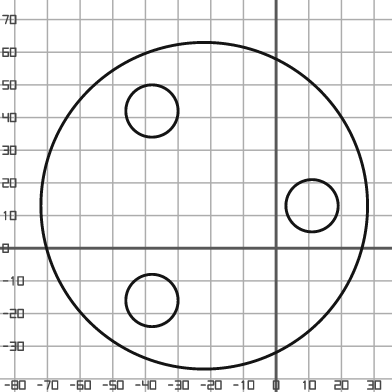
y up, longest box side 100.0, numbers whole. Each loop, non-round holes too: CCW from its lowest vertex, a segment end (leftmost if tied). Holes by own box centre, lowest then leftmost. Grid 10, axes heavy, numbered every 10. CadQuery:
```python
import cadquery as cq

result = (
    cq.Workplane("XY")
    .moveTo(-22.0, 13.0)
    .circle(50.0)
    .moveTo(-38.0, -16.0)
    .circle(8.0)
    .moveTo(11.0, 13.0)
    .circle(8.0)
    .moveTo(-38.0, 42.0)
    .circle(8.0)
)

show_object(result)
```